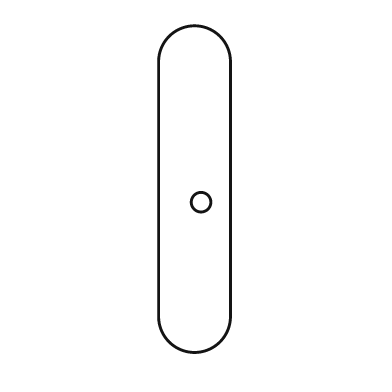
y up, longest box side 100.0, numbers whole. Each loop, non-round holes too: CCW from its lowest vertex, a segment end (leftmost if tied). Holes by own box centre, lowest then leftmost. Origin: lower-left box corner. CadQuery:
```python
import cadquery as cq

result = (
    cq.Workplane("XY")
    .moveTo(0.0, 11.0)
    .threePointArc((11.0, 0.0), (22.0, 11.0))
    .lineTo(22.0, 89.0)
    .threePointArc((11.0, 100.0), (0.0, 89.0))
    .close()
    .moveTo(13.0, 46.0)
    .circle(3.0)
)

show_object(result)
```